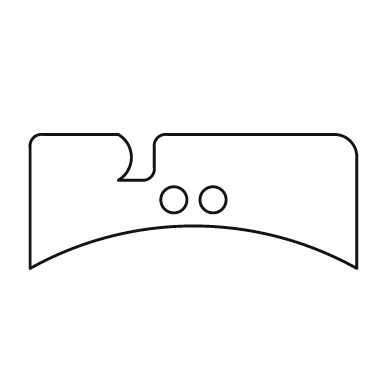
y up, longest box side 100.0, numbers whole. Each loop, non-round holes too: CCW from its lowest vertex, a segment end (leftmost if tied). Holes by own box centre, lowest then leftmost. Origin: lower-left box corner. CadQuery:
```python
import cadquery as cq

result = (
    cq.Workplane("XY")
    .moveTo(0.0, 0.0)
    .threePointArc((50.0, 13.0), (100.0, 0.0))
    .lineTo(100.0, 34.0)
    .threePointArc((98.0, 39.0), (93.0, 41.0))
    .lineTo(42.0, 41.0)
    .threePointArc((39.0, 40.0), (38.0, 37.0))
    .lineTo(38.0, 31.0)
    .threePointArc((37.0, 28.0), (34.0, 27.0))
    .lineTo(27.0, 27.0)
    .threePointArc((31.0, 34.0), (27.0, 41.0))
    .lineTo(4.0, 41.0)
    .threePointArc((1.0, 40.0), (0.0, 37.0))
    .close()
    .moveTo(44.0, 21.0)
    .circle(4.0)
    .moveTo(56.0, 21.0)
    .circle(4.0)
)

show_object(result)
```